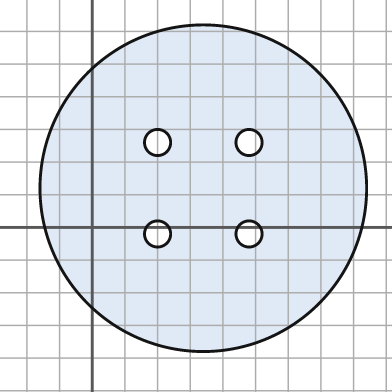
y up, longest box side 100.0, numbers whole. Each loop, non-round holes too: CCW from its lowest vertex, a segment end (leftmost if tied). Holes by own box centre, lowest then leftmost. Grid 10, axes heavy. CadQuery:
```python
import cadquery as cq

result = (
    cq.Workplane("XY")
    .moveTo(34.0, 12.0)
    .circle(50.0)
    .moveTo(20.0, -2.0)
    .circle(4.0)
    .moveTo(48.0, -2.0)
    .circle(4.0)
    .moveTo(20.0, 26.0)
    .circle(4.0)
    .moveTo(48.0, 26.0)
    .circle(4.0)
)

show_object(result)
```